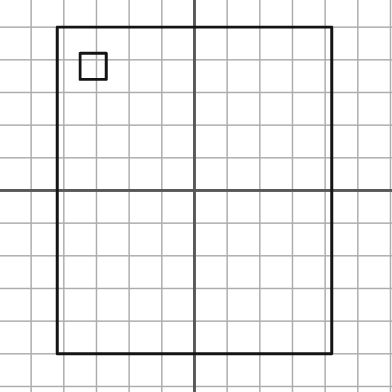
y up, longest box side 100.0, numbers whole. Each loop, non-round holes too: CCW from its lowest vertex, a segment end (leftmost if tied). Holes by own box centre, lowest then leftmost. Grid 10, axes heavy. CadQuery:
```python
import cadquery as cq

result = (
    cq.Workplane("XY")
    .moveTo(-42.0, -50.0)
    .lineTo(42.0, -50.0)
    .lineTo(42.0, 50.0)
    .lineTo(-42.0, 50.0)
    .close()
    .moveTo(-35.0, 34.0)
    .lineTo(-27.0, 34.0)
    .lineTo(-27.0, 42.0)
    .lineTo(-35.0, 42.0)
    .close()
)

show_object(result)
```